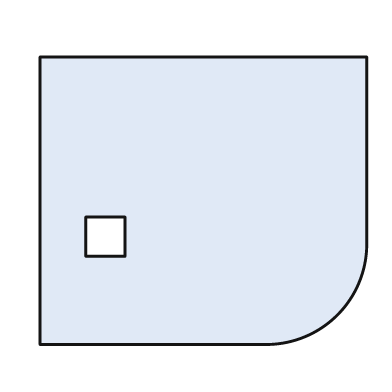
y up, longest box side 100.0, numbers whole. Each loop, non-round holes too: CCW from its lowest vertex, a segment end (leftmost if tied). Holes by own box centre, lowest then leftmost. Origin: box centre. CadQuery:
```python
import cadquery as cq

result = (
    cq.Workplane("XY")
    .moveTo(-50.0, -44.0)
    .lineTo(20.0, -44.0)
    .threePointArc((41.0, -35.0), (50.0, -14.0))
    .lineTo(50.0, 44.0)
    .lineTo(-50.0, 44.0)
    .close()
    .moveTo(-36.0, -17.0)
    .lineTo(-24.0, -17.0)
    .lineTo(-24.0, -5.0)
    .lineTo(-36.0, -5.0)
    .close()
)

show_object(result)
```